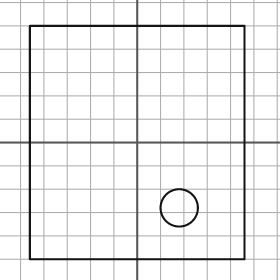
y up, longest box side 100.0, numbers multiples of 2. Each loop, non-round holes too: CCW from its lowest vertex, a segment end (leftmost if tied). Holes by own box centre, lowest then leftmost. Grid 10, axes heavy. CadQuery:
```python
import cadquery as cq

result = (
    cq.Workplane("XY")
    .moveTo(-46.0, -50.0)
    .lineTo(46.0, -50.0)
    .lineTo(46.0, 50.0)
    .lineTo(-46.0, 50.0)
    .close()
    .moveTo(18.0, -28.0)
    .circle(8.0)
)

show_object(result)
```